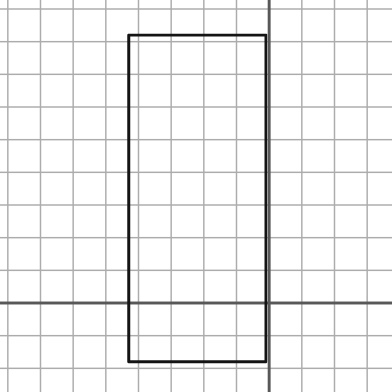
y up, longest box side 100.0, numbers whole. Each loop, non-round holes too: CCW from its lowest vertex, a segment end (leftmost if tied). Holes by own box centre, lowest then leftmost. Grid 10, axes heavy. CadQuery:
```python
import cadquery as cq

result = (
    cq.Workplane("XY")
    .moveTo(-43.0, -18.0)
    .lineTo(-1.0, -18.0)
    .lineTo(-1.0, 82.0)
    .lineTo(-43.0, 82.0)
    .close()
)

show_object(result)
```